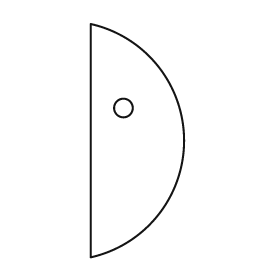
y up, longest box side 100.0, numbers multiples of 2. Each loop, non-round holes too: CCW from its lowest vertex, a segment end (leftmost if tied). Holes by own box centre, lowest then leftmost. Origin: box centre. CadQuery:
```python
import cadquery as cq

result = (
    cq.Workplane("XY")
    .moveTo(-20.0, -50.0)
    .threePointArc((20.0, 0.0), (-20.0, 50.0))
    .close()
    .moveTo(-6.0, 14.0)
    .circle(4.0)
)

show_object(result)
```